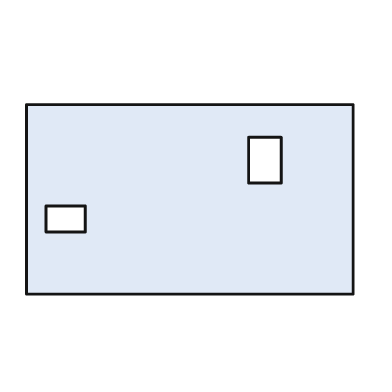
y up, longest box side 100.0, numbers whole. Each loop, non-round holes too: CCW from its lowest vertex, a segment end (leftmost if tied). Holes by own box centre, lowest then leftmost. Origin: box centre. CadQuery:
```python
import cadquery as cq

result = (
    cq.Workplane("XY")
    .moveTo(-50.0, -29.0)
    .lineTo(50.0, -29.0)
    .lineTo(50.0, 29.0)
    .lineTo(-50.0, 29.0)
    .close()
    .moveTo(-44.0, -10.0)
    .lineTo(-32.0, -10.0)
    .lineTo(-32.0, -2.0)
    .lineTo(-44.0, -2.0)
    .close()
    .moveTo(18.0, 5.0)
    .lineTo(28.0, 5.0)
    .lineTo(28.0, 19.0)
    .lineTo(18.0, 19.0)
    .close()
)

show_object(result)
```